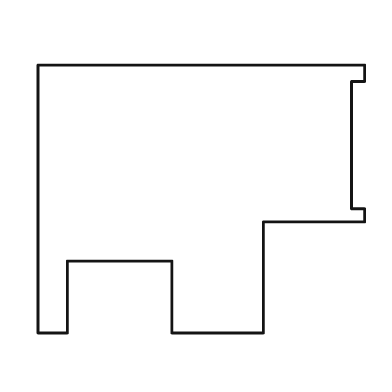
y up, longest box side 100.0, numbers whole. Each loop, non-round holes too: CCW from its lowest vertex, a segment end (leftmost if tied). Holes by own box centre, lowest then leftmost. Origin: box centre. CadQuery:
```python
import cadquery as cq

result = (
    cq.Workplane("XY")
    .moveTo(-50.0, -41.0)
    .lineTo(-41.0, -41.0)
    .lineTo(-41.0, -19.0)
    .lineTo(-9.0, -19.0)
    .lineTo(-9.0, -41.0)
    .lineTo(19.0, -41.0)
    .lineTo(19.0, -7.0)
    .lineTo(50.0, -7.0)
    .lineTo(50.0, -3.0)
    .lineTo(46.0, -3.0)
    .lineTo(46.0, 36.0)
    .lineTo(50.0, 36.0)
    .lineTo(50.0, 41.0)
    .lineTo(-50.0, 41.0)
    .close()
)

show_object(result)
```